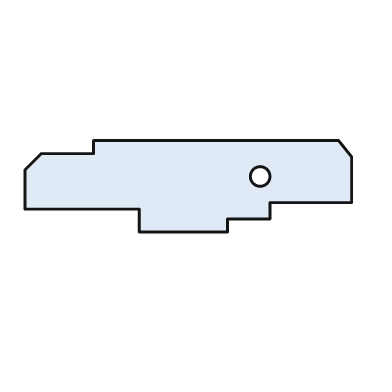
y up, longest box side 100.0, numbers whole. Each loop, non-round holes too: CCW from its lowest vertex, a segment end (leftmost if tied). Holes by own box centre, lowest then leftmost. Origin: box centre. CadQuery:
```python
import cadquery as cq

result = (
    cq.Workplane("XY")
    .moveTo(-15.0, -14.0)
    .lineTo(12.0, -14.0)
    .lineTo(12.0, -10.0)
    .lineTo(25.0, -10.0)
    .lineTo(25.0, -5.0)
    .lineTo(50.0, -5.0)
    .lineTo(50.0, 9.0)
    .lineTo(46.0, 14.0)
    .lineTo(-29.0, 14.0)
    .lineTo(-29.0, 10.0)
    .lineTo(-45.0, 10.0)
    .lineTo(-50.0, 5.0)
    .lineTo(-50.0, -7.0)
    .lineTo(-15.0, -7.0)
    .close()
    .moveTo(22.0, 3.0)
    .circle(3.0)
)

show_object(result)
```